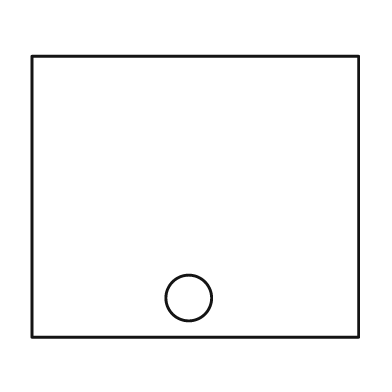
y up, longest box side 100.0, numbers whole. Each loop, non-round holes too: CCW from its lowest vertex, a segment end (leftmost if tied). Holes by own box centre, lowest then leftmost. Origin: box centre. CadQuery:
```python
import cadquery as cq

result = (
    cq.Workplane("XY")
    .moveTo(-50.0, -43.0)
    .lineTo(50.0, -43.0)
    .lineTo(50.0, 43.0)
    .lineTo(-50.0, 43.0)
    .close()
    .moveTo(-2.0, -31.0)
    .circle(7.0)
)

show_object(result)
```